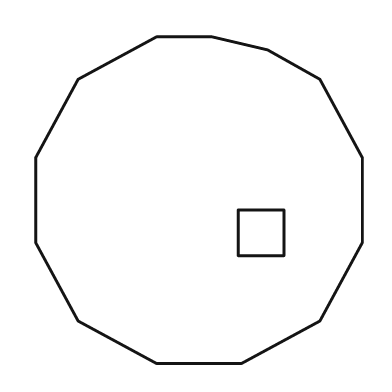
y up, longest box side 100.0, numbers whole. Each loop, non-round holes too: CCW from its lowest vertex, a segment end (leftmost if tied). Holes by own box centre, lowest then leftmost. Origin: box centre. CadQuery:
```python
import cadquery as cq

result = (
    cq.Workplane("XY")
    .moveTo(-13.0, -50.0)
    .lineTo(13.0, -50.0)
    .lineTo(37.0, -37.0)
    .lineTo(50.0, -13.0)
    .lineTo(50.0, 13.0)
    .lineTo(37.0, 37.0)
    .lineTo(21.0, 46.0)
    .lineTo(4.0, 50.0)
    .lineTo(-13.0, 50.0)
    .lineTo(-37.0, 37.0)
    .lineTo(-50.0, 13.0)
    .lineTo(-50.0, -13.0)
    .lineTo(-37.0, -37.0)
    .close()
    .moveTo(12.0, -17.0)
    .lineTo(26.0, -17.0)
    .lineTo(26.0, -3.0)
    .lineTo(12.0, -3.0)
    .close()
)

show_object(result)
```